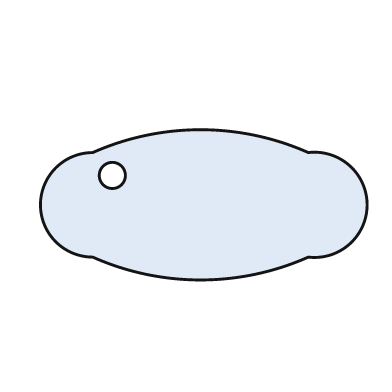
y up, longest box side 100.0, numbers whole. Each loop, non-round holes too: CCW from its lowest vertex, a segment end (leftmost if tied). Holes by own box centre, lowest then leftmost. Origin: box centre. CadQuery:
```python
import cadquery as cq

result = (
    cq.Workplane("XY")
    .moveTo(-34.0, -16.0)
    .threePointArc((-1.0, -23.0), (32.0, -16.0))
    .threePointArc((50.0, 0.0), (32.0, 16.0))
    .threePointArc((-1.0, 23.0), (-34.0, 16.0))
    .threePointArc((-50.0, 0.0), (-34.0, -16.0))
    .close()
    .moveTo(-28.0, 9.0)
    .circle(4.0)
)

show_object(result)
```